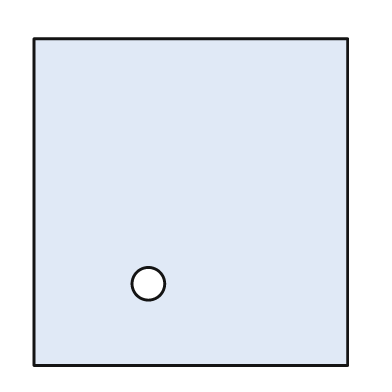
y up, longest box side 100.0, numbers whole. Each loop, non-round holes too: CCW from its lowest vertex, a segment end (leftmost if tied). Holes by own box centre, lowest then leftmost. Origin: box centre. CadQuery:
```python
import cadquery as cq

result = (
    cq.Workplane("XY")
    .moveTo(-48.0, -50.0)
    .lineTo(48.0, -50.0)
    .lineTo(48.0, 50.0)
    .lineTo(-48.0, 50.0)
    .close()
    .moveTo(-13.0, -25.0)
    .circle(5.0)
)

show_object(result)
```